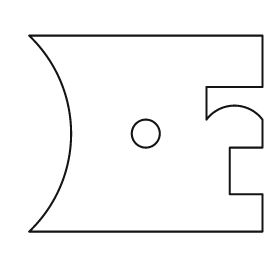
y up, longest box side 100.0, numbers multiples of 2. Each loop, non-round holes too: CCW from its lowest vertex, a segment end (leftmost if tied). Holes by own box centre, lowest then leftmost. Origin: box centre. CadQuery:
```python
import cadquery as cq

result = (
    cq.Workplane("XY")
    .moveTo(-50.0, -42.0)
    .lineTo(50.0, -42.0)
    .lineTo(50.0, -26.0)
    .lineTo(36.0, -26.0)
    .lineTo(36.0, -6.0)
    .lineTo(50.0, -6.0)
    .lineTo(50.0, 6.0)
    .threePointArc((38.0, 12.0), (26.0, 6.0))
    .lineTo(26.0, 20.0)
    .lineTo(50.0, 20.0)
    .lineTo(50.0, 42.0)
    .lineTo(-50.0, 42.0)
    .threePointArc((-32.0, 0.0), (-50.0, -42.0))
    .close()
    .moveTo(0.0, 0.0)
    .circle(6.0)
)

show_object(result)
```